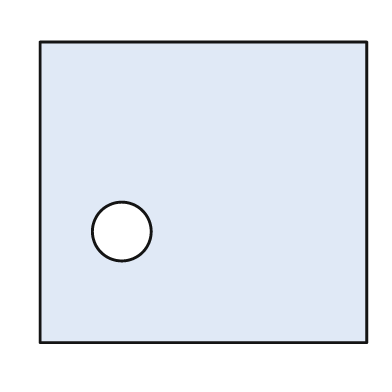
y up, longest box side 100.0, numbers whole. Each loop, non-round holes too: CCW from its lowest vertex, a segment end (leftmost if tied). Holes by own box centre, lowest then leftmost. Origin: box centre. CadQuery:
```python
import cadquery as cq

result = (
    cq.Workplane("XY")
    .moveTo(-50.0, -46.0)
    .lineTo(50.0, -46.0)
    .lineTo(50.0, 46.0)
    .lineTo(-50.0, 46.0)
    .close()
    .moveTo(-25.0, -12.0)
    .circle(9.0)
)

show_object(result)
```